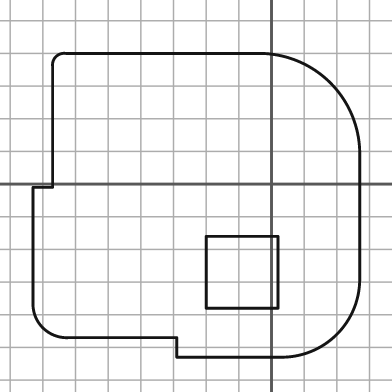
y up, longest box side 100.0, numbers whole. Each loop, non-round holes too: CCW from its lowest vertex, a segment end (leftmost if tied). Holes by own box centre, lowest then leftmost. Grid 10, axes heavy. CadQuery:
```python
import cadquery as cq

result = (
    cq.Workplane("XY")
    .moveTo(-29.0, -53.0)
    .lineTo(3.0, -53.0)
    .threePointArc((20.0, -46.0), (27.0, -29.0))
    .lineTo(27.0, 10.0)
    .threePointArc((18.0, 31.0), (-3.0, 40.0))
    .lineTo(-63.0, 40.0)
    .threePointArc((-66.0, 39.0), (-67.0, 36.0))
    .lineTo(-67.0, -1.0)
    .lineTo(-73.0, -1.0)
    .lineTo(-73.0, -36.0)
    .threePointArc((-70.0, -44.0), (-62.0, -47.0))
    .lineTo(-29.0, -47.0)
    .close()
    .moveTo(-20.0, -38.0)
    .lineTo(2.0, -38.0)
    .lineTo(2.0, -16.0)
    .lineTo(-20.0, -16.0)
    .close()
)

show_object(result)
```